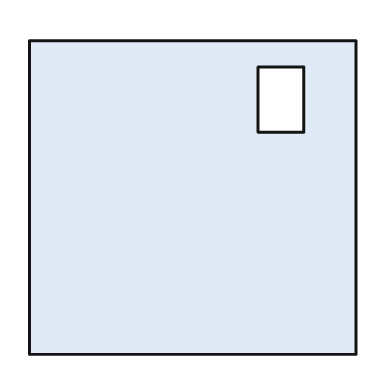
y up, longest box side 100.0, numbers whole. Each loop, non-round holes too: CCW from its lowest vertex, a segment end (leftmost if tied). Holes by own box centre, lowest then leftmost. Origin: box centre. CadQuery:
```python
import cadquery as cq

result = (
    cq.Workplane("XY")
    .moveTo(-50.0, -48.0)
    .lineTo(50.0, -48.0)
    .lineTo(50.0, 48.0)
    .lineTo(-50.0, 48.0)
    .close()
    .moveTo(20.0, 20.0)
    .lineTo(34.0, 20.0)
    .lineTo(34.0, 40.0)
    .lineTo(20.0, 40.0)
    .close()
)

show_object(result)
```